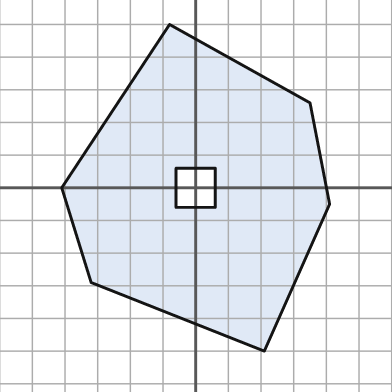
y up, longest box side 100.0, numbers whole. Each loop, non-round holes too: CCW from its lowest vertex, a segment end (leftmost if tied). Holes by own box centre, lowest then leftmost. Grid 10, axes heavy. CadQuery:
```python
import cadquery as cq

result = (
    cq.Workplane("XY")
    .moveTo(21.0, -50.0)
    .lineTo(41.0, -5.0)
    .lineTo(35.0, 26.0)
    .lineTo(-8.0, 50.0)
    .lineTo(-41.0, 0.0)
    .lineTo(-32.0, -29.0)
    .close()
    .moveTo(-6.0, -6.0)
    .lineTo(6.0, -6.0)
    .lineTo(6.0, 6.0)
    .lineTo(-6.0, 6.0)
    .close()
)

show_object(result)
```